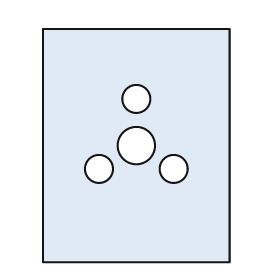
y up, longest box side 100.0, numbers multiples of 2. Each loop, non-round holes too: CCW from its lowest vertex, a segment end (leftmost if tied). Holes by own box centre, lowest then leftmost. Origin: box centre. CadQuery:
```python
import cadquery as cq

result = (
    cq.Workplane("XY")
    .moveTo(-40.0, -50.0)
    .lineTo(40.0, -50.0)
    .lineTo(40.0, 50.0)
    .lineTo(-40.0, 50.0)
    .close()
    .moveTo(-16.0, -10.0)
    .circle(6.0)
    .moveTo(16.0, -10.0)
    .circle(6.0)
    .moveTo(0.0, 0.0)
    .circle(8.0)
    .moveTo(0.0, 20.0)
    .circle(6.0)
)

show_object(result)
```